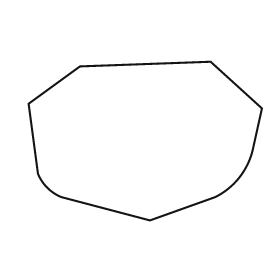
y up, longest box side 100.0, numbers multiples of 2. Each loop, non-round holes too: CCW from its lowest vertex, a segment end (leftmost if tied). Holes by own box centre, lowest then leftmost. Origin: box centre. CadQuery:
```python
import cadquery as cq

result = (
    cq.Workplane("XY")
    .moveTo(2.0, -34.0)
    .lineTo(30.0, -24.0)
    .threePointArc((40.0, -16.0), (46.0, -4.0))
    .lineTo(50.0, 14.0)
    .lineTo(28.0, 34.0)
    .lineTo(-28.0, 32.0)
    .lineTo(-50.0, 16.0)
    .lineTo(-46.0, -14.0)
    .threePointArc((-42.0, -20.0), (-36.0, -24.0))
    .close()
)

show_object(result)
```